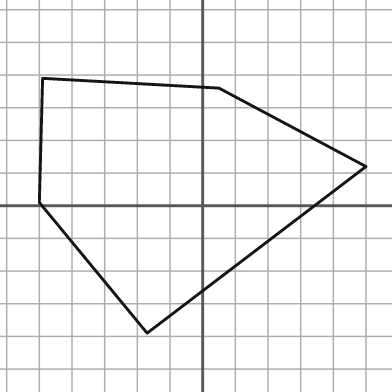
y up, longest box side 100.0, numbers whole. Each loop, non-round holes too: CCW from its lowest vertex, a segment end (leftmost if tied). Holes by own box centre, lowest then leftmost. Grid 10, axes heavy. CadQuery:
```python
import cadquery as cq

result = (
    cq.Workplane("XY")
    .moveTo(-17.0, -39.0)
    .lineTo(50.0, 12.0)
    .lineTo(5.0, 36.0)
    .lineTo(-49.0, 39.0)
    .lineTo(-50.0, 1.0)
    .close()
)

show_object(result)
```